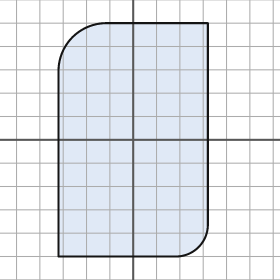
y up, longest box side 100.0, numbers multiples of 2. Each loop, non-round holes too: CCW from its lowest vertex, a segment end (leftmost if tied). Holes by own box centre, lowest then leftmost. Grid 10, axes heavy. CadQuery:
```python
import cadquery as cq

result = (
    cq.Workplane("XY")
    .moveTo(-32.0, -50.0)
    .lineTo(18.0, -50.0)
    .threePointArc((28.0, -46.0), (32.0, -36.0))
    .lineTo(32.0, 50.0)
    .lineTo(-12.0, 50.0)
    .threePointArc((-26.0, 44.0), (-32.0, 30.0))
    .close()
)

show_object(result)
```